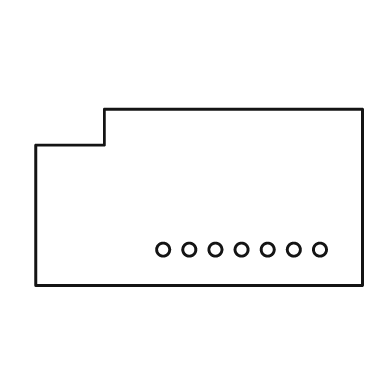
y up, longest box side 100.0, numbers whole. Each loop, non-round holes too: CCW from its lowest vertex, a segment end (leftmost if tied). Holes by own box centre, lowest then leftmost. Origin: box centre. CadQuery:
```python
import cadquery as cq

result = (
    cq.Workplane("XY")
    .moveTo(-50.0, -27.0)
    .lineTo(50.0, -27.0)
    .lineTo(50.0, 27.0)
    .lineTo(-29.0, 27.0)
    .lineTo(-29.0, 16.0)
    .lineTo(-50.0, 16.0)
    .close()
    .moveTo(-11.0, -16.0)
    .circle(2.0)
    .moveTo(-3.0, -16.0)
    .circle(2.0)
    .moveTo(5.0, -16.0)
    .circle(2.0)
    .moveTo(13.0, -16.0)
    .circle(2.0)
    .moveTo(21.0, -16.0)
    .circle(2.0)
    .moveTo(29.0, -16.0)
    .circle(2.0)
    .moveTo(37.0, -16.0)
    .circle(2.0)
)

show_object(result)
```